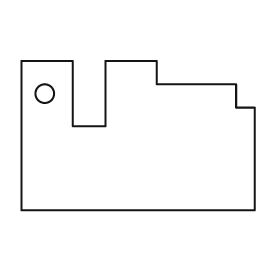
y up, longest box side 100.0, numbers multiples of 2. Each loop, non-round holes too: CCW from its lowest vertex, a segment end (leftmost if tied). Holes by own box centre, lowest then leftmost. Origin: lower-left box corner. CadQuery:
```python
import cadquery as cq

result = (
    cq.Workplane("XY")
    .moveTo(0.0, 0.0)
    .lineTo(100.0, 0.0)
    .lineTo(100.0, 44.0)
    .lineTo(92.0, 44.0)
    .lineTo(92.0, 54.0)
    .lineTo(58.0, 54.0)
    .lineTo(58.0, 64.0)
    .lineTo(36.0, 64.0)
    .lineTo(36.0, 36.0)
    .lineTo(22.0, 36.0)
    .lineTo(22.0, 64.0)
    .lineTo(0.0, 64.0)
    .close()
    .moveTo(10.0, 50.0)
    .circle(4.0)
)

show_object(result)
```